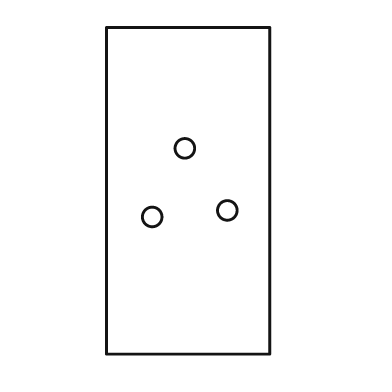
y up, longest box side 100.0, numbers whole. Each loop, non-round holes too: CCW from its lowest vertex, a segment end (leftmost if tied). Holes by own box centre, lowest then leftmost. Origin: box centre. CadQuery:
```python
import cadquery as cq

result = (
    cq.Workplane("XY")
    .moveTo(-25.0, -50.0)
    .lineTo(25.0, -50.0)
    .lineTo(25.0, 50.0)
    .lineTo(-25.0, 50.0)
    .close()
    .moveTo(-11.0, -8.0)
    .circle(3.0)
    .moveTo(12.0, -6.0)
    .circle(3.0)
    .moveTo(-1.0, 13.0)
    .circle(3.0)
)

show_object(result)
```